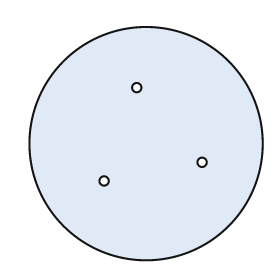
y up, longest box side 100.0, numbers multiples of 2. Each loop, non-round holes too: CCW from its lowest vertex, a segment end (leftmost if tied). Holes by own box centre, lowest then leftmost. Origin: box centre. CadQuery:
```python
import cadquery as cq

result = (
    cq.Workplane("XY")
    .moveTo(0.0, 0.0)
    .circle(50.0)
    .moveTo(-18.0, -16.0)
    .circle(2.0)
    .moveTo(24.0, -8.0)
    .circle(2.0)
    .moveTo(-4.0, 24.0)
    .circle(2.0)
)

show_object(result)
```